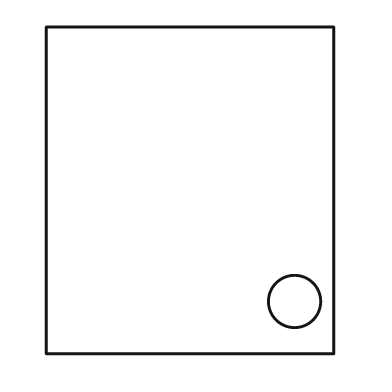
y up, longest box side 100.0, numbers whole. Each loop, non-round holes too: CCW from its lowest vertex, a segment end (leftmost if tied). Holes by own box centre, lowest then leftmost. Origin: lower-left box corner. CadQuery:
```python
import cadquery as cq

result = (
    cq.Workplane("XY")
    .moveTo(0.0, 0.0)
    .lineTo(88.0, 0.0)
    .lineTo(88.0, 100.0)
    .lineTo(0.0, 100.0)
    .close()
    .moveTo(76.0, 16.0)
    .circle(8.0)
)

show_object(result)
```